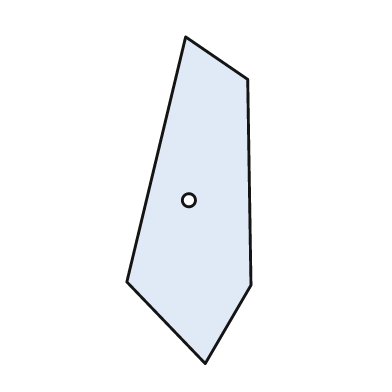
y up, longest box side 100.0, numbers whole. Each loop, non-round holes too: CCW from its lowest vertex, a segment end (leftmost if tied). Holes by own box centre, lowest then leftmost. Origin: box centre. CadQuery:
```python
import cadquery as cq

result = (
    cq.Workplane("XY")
    .moveTo(5.0, -50.0)
    .lineTo(19.0, -26.0)
    .lineTo(18.0, 37.0)
    .lineTo(-1.0, 50.0)
    .lineTo(-19.0, -25.0)
    .close()
    .moveTo(0.0, 0.0)
    .circle(2.0)
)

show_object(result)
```